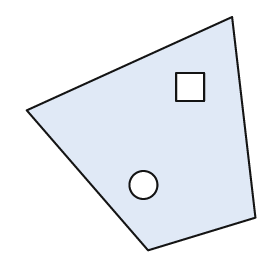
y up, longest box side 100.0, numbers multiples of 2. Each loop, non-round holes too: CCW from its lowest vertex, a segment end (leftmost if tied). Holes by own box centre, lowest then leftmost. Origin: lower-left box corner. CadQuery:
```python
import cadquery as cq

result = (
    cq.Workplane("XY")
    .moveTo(52.0, 0.0)
    .lineTo(98.0, 14.0)
    .lineTo(88.0, 100.0)
    .lineTo(0.0, 60.0)
    .close()
    .moveTo(50.0, 28.0)
    .circle(6.0)
    .moveTo(64.0, 64.0)
    .lineTo(76.0, 64.0)
    .lineTo(76.0, 76.0)
    .lineTo(64.0, 76.0)
    .close()
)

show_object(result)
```